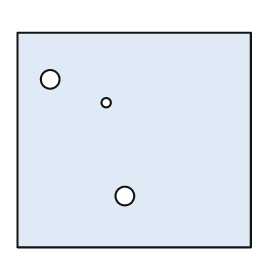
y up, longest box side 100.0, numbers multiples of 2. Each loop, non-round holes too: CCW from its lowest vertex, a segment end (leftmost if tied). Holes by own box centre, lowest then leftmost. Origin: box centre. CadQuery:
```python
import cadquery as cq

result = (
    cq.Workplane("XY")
    .moveTo(-50.0, -46.0)
    .lineTo(50.0, -46.0)
    .lineTo(50.0, 46.0)
    .lineTo(-50.0, 46.0)
    .close()
    .moveTo(-4.0, -24.0)
    .circle(4.0)
    .moveTo(-12.0, 16.0)
    .circle(2.0)
    .moveTo(-36.0, 26.0)
    .circle(4.0)
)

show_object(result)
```